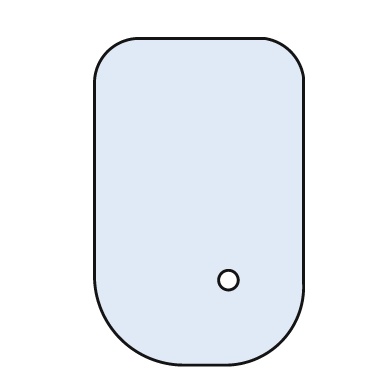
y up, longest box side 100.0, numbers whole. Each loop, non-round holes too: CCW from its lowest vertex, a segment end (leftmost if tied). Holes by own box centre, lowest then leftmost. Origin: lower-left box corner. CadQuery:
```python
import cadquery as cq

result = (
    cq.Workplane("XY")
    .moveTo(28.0, 0.0)
    .lineTo(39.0, 0.0)
    .threePointArc((57.0, 7.0), (64.0, 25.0))
    .lineTo(64.0, 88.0)
    .threePointArc((60.0, 96.0), (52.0, 100.0))
    .lineTo(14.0, 100.0)
    .threePointArc((4.0, 96.0), (0.0, 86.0))
    .lineTo(0.0, 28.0)
    .threePointArc((8.0, 8.0), (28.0, 0.0))
    .close()
    .moveTo(41.0, 26.0)
    .circle(3.0)
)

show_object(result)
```